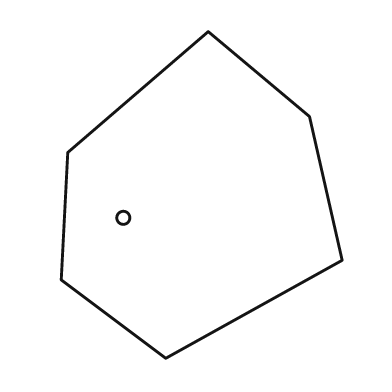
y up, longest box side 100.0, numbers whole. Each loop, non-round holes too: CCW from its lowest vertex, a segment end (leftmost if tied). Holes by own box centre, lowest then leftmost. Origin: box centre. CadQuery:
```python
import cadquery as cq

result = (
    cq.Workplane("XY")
    .moveTo(-11.0, -50.0)
    .lineTo(43.0, -20.0)
    .lineTo(33.0, 24.0)
    .lineTo(2.0, 50.0)
    .lineTo(-41.0, 13.0)
    .lineTo(-43.0, -26.0)
    .close()
    .moveTo(-24.0, -7.0)
    .circle(2.0)
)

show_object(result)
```